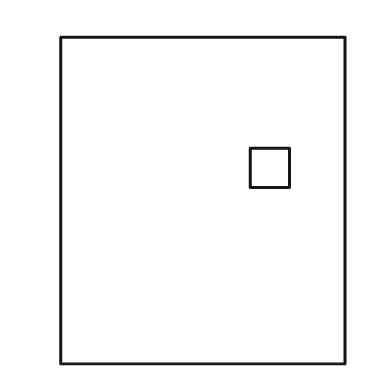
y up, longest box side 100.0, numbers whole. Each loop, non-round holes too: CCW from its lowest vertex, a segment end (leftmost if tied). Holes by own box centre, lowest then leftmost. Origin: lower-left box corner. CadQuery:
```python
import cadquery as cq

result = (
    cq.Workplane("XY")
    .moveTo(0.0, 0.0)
    .lineTo(87.0, 0.0)
    .lineTo(87.0, 100.0)
    .lineTo(0.0, 100.0)
    .close()
    .moveTo(58.0, 54.0)
    .lineTo(70.0, 54.0)
    .lineTo(70.0, 66.0)
    .lineTo(58.0, 66.0)
    .close()
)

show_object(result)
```